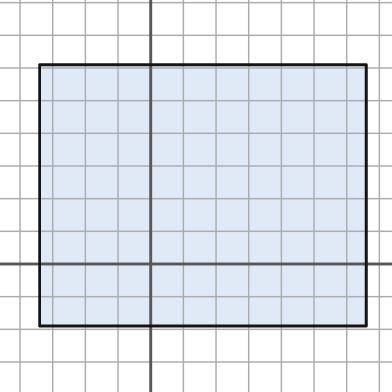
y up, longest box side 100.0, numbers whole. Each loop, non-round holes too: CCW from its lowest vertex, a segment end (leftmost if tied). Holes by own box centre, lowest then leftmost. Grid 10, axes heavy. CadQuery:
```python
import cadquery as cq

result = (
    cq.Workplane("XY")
    .moveTo(-34.0, -19.0)
    .lineTo(66.0, -19.0)
    .lineTo(66.0, 61.0)
    .lineTo(-34.0, 61.0)
    .close()
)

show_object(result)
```